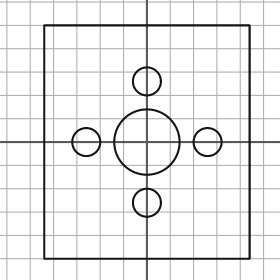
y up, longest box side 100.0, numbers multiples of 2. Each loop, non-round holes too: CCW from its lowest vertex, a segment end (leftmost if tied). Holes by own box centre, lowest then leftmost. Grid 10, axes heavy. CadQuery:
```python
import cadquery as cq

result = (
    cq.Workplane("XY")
    .moveTo(-44.0, -50.0)
    .lineTo(44.0, -50.0)
    .lineTo(44.0, 50.0)
    .lineTo(-44.0, 50.0)
    .close()
    .moveTo(0.0, -26.0)
    .circle(6.0)
    .moveTo(-26.0, 0.0)
    .circle(6.0)
    .moveTo(0.0, 0.0)
    .circle(14.0)
    .moveTo(26.0, 0.0)
    .circle(6.0)
    .moveTo(0.0, 26.0)
    .circle(6.0)
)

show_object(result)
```